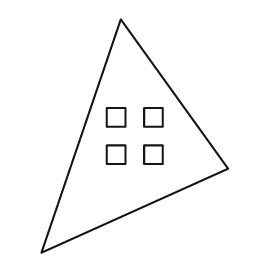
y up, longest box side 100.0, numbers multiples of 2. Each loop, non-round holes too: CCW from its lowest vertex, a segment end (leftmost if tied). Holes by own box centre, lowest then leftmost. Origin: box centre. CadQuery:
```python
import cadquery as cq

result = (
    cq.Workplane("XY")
    .moveTo(-40.0, -50.0)
    .lineTo(40.0, -14.0)
    .lineTo(-6.0, 50.0)
    .close()
    .moveTo(-12.0, -12.0)
    .lineTo(-4.0, -12.0)
    .lineTo(-4.0, -4.0)
    .lineTo(-12.0, -4.0)
    .close()
    .moveTo(4.0, -12.0)
    .lineTo(12.0, -12.0)
    .lineTo(12.0, -4.0)
    .lineTo(4.0, -4.0)
    .close()
    .moveTo(-12.0, 4.0)
    .lineTo(-4.0, 4.0)
    .lineTo(-4.0, 12.0)
    .lineTo(-12.0, 12.0)
    .close()
    .moveTo(4.0, 4.0)
    .lineTo(12.0, 4.0)
    .lineTo(12.0, 12.0)
    .lineTo(4.0, 12.0)
    .close()
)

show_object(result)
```